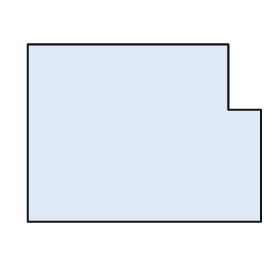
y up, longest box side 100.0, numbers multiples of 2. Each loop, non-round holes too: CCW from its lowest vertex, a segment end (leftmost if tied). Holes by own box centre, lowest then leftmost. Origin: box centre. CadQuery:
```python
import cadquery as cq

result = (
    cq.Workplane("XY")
    .moveTo(-50.0, -38.0)
    .lineTo(50.0, -38.0)
    .lineTo(50.0, 10.0)
    .lineTo(36.0, 10.0)
    .lineTo(36.0, 38.0)
    .lineTo(-50.0, 38.0)
    .close()
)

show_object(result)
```